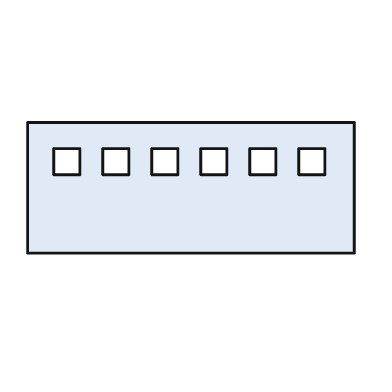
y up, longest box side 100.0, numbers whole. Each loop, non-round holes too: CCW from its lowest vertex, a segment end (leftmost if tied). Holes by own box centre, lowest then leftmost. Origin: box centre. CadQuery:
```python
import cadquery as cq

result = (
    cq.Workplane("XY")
    .moveTo(-50.0, -20.0)
    .lineTo(50.0, -20.0)
    .lineTo(50.0, 20.0)
    .lineTo(-50.0, 20.0)
    .close()
    .moveTo(-42.0, 4.0)
    .lineTo(-34.0, 4.0)
    .lineTo(-34.0, 12.0)
    .lineTo(-42.0, 12.0)
    .close()
    .moveTo(-27.0, 4.0)
    .lineTo(-19.0, 4.0)
    .lineTo(-19.0, 12.0)
    .lineTo(-27.0, 12.0)
    .close()
    .moveTo(-12.0, 4.0)
    .lineTo(-4.0, 4.0)
    .lineTo(-4.0, 12.0)
    .lineTo(-12.0, 12.0)
    .close()
    .moveTo(3.0, 4.0)
    .lineTo(11.0, 4.0)
    .lineTo(11.0, 12.0)
    .lineTo(3.0, 12.0)
    .close()
    .moveTo(18.0, 4.0)
    .lineTo(26.0, 4.0)
    .lineTo(26.0, 12.0)
    .lineTo(18.0, 12.0)
    .close()
    .moveTo(33.0, 4.0)
    .lineTo(41.0, 4.0)
    .lineTo(41.0, 12.0)
    .lineTo(33.0, 12.0)
    .close()
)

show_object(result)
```